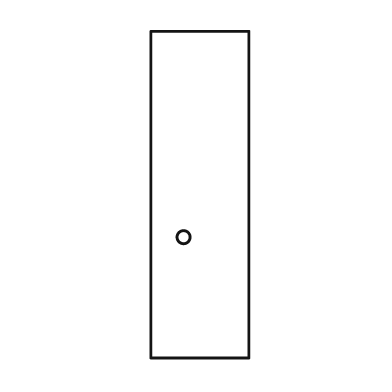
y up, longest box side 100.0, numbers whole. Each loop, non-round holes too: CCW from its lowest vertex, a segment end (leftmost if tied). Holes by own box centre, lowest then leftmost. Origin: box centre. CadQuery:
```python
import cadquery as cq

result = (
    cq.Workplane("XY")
    .moveTo(-15.0, -50.0)
    .lineTo(15.0, -50.0)
    .lineTo(15.0, 50.0)
    .lineTo(-15.0, 50.0)
    .close()
    .moveTo(-5.0, -13.0)
    .circle(2.0)
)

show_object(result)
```